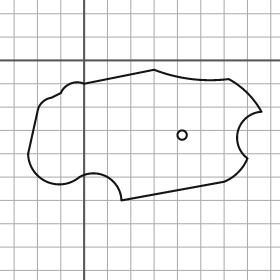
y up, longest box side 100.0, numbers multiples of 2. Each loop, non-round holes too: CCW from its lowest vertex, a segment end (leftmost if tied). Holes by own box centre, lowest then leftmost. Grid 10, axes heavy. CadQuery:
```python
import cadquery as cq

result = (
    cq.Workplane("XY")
    .moveTo(16.0, -60.0)
    .lineTo(60.0, -52.0)
    .threePointArc((66.0, -48.0), (70.0, -42.0))
    .threePointArc((66.0, -30.0), (76.0, -22.0))
    .threePointArc((70.0, -14.0), (62.0, -8.0))
    .threePointArc((46.0, -8.0), (30.0, -4.0))
    .lineTo(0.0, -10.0)
    .threePointArc((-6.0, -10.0), (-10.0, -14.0))
    .lineTo(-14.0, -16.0)
    .threePointArc((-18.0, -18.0), (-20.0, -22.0))
    .lineTo(-24.0, -40.0)
    .threePointArc((-16.0, -52.0), (-2.0, -50.0))
    .threePointArc((10.0, -50.0), (16.0, -60.0))
    .close()
    .moveTo(42.0, -32.0)
    .circle(2.0)
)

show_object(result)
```